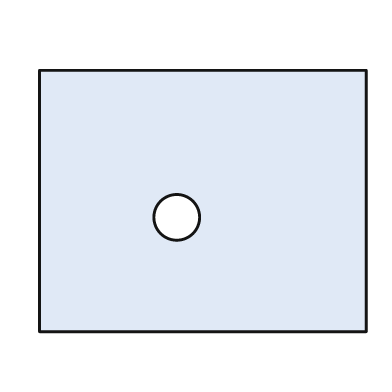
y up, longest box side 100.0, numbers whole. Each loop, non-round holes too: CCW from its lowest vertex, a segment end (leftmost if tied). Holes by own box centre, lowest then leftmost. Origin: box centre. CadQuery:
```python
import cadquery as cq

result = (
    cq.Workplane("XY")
    .moveTo(-50.0, -40.0)
    .lineTo(50.0, -40.0)
    .lineTo(50.0, 40.0)
    .lineTo(-50.0, 40.0)
    .close()
    .moveTo(-8.0, -5.0)
    .circle(7.0)
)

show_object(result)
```